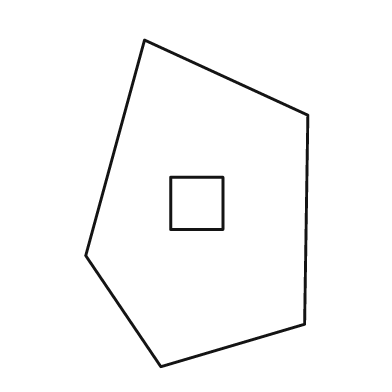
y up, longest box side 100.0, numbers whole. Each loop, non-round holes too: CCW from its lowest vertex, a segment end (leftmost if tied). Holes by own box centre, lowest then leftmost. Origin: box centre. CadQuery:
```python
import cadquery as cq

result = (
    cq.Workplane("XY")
    .moveTo(-11.0, -50.0)
    .lineTo(33.0, -37.0)
    .lineTo(34.0, 27.0)
    .lineTo(-16.0, 50.0)
    .lineTo(-34.0, -16.0)
    .close()
    .moveTo(-8.0, -8.0)
    .lineTo(8.0, -8.0)
    .lineTo(8.0, 8.0)
    .lineTo(-8.0, 8.0)
    .close()
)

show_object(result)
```